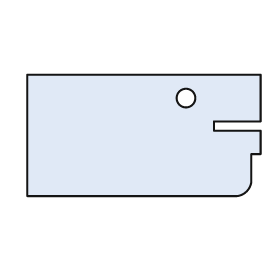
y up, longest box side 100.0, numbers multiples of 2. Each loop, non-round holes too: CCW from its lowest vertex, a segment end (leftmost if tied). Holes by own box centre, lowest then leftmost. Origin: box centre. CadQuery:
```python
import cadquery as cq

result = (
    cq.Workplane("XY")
    .moveTo(-50.0, -26.0)
    .lineTo(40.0, -26.0)
    .threePointArc((44.0, -24.0), (46.0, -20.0))
    .lineTo(46.0, -8.0)
    .lineTo(50.0, -8.0)
    .lineTo(50.0, 2.0)
    .lineTo(30.0, 2.0)
    .lineTo(30.0, 6.0)
    .lineTo(50.0, 6.0)
    .lineTo(50.0, 26.0)
    .lineTo(-50.0, 26.0)
    .close()
    .moveTo(18.0, 16.0)
    .circle(4.0)
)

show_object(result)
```